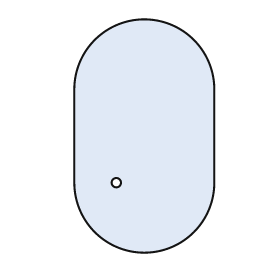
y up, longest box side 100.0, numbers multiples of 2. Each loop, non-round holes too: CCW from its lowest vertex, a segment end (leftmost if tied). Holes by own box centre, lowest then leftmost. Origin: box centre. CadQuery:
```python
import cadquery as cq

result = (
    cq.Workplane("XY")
    .moveTo(-30.0, -20.0)
    .threePointArc((0.0, -50.0), (30.0, -20.0))
    .lineTo(30.0, 20.0)
    .threePointArc((0.0, 50.0), (-30.0, 20.0))
    .close()
    .moveTo(-12.0, -20.0)
    .circle(2.0)
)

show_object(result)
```